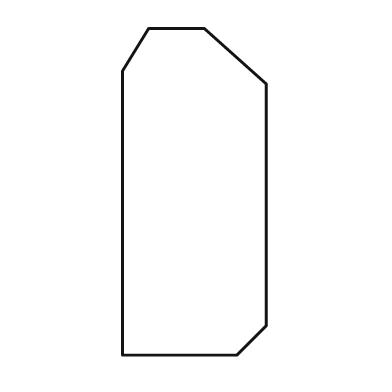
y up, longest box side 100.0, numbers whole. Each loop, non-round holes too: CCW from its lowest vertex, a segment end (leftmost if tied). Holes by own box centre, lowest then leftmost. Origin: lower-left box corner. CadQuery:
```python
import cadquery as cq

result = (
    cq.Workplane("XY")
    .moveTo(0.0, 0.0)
    .lineTo(35.0, 0.0)
    .lineTo(44.0, 9.0)
    .lineTo(44.0, 83.0)
    .lineTo(25.0, 100.0)
    .lineTo(8.0, 100.0)
    .lineTo(0.0, 87.0)
    .close()
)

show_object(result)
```